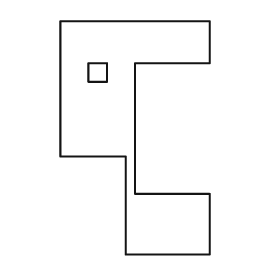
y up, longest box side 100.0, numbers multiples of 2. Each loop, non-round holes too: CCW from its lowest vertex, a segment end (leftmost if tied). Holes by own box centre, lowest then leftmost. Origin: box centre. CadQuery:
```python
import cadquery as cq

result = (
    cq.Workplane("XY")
    .moveTo(-4.0, -50.0)
    .lineTo(32.0, -50.0)
    .lineTo(32.0, -24.0)
    .lineTo(0.0, -24.0)
    .lineTo(0.0, 32.0)
    .lineTo(32.0, 32.0)
    .lineTo(32.0, 50.0)
    .lineTo(-32.0, 50.0)
    .lineTo(-32.0, -8.0)
    .lineTo(-4.0, -8.0)
    .close()
    .moveTo(-20.0, 24.0)
    .lineTo(-12.0, 24.0)
    .lineTo(-12.0, 32.0)
    .lineTo(-20.0, 32.0)
    .close()
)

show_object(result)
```